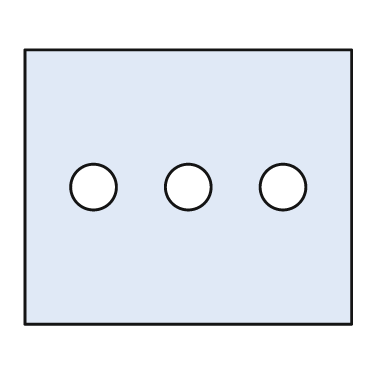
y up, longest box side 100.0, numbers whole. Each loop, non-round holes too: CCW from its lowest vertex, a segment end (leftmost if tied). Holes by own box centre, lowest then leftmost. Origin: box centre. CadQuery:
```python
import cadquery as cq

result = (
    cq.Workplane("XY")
    .moveTo(-50.0, -42.0)
    .lineTo(50.0, -42.0)
    .lineTo(50.0, 42.0)
    .lineTo(-50.0, 42.0)
    .close()
    .moveTo(-29.0, 0.0)
    .circle(7.0)
    .moveTo(0.0, 0.0)
    .circle(7.0)
    .moveTo(29.0, 0.0)
    .circle(7.0)
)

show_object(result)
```